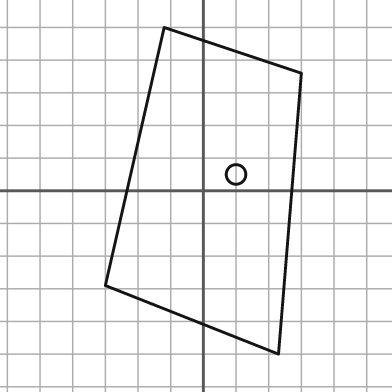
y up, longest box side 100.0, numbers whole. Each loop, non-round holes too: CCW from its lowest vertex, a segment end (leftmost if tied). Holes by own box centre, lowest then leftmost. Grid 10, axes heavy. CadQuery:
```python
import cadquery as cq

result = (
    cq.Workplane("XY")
    .moveTo(23.0, -50.0)
    .lineTo(30.0, 36.0)
    .lineTo(-12.0, 50.0)
    .lineTo(-30.0, -29.0)
    .close()
    .moveTo(10.0, 5.0)
    .circle(3.0)
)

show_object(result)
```